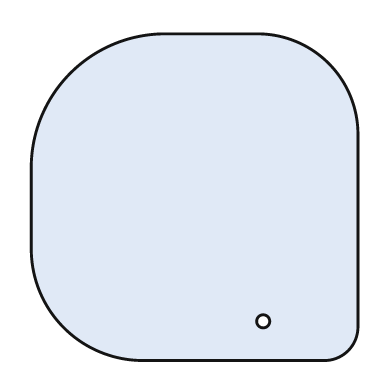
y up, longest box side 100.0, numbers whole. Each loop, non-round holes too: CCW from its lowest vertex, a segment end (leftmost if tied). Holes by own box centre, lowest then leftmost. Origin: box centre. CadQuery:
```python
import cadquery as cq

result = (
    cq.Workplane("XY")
    .moveTo(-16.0, -50.0)
    .lineTo(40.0, -50.0)
    .threePointArc((47.0, -47.0), (50.0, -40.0))
    .lineTo(50.0, 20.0)
    .threePointArc((41.0, 41.0), (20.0, 50.0))
    .lineTo(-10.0, 50.0)
    .threePointArc((-38.0, 38.0), (-50.0, 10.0))
    .lineTo(-50.0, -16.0)
    .threePointArc((-40.0, -40.0), (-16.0, -50.0))
    .close()
    .moveTo(21.0, -38.0)
    .circle(2.0)
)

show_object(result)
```